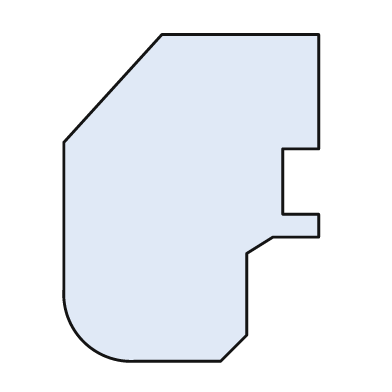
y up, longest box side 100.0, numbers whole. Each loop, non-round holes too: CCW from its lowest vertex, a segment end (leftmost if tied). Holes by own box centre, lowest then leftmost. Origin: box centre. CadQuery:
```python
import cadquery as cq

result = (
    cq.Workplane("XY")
    .moveTo(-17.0, -50.0)
    .lineTo(9.0, -50.0)
    .lineTo(17.0, -42.0)
    .lineTo(17.0, -17.0)
    .lineTo(25.0, -12.0)
    .lineTo(39.0, -12.0)
    .lineTo(39.0, -5.0)
    .lineTo(28.0, -5.0)
    .lineTo(28.0, 15.0)
    .lineTo(39.0, 15.0)
    .lineTo(39.0, 50.0)
    .lineTo(-9.0, 50.0)
    .lineTo(-39.0, 17.0)
    .lineTo(-39.0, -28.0)
    .threePointArc((-33.0, -44.0), (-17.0, -50.0))
    .close()
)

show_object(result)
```